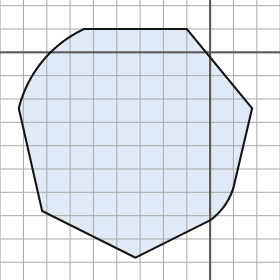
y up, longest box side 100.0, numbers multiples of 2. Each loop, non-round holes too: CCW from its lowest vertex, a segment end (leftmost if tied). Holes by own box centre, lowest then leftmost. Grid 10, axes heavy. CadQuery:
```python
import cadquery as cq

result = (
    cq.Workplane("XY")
    .moveTo(-32.0, -88.0)
    .lineTo(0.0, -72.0)
    .threePointArc((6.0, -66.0), (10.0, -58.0))
    .lineTo(18.0, -24.0)
    .lineTo(-10.0, 10.0)
    .lineTo(-54.0, 10.0)
    .threePointArc((-72.0, -4.0), (-82.0, -24.0))
    .lineTo(-72.0, -68.0)
    .close()
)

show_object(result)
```